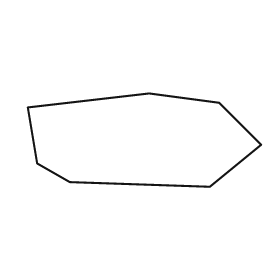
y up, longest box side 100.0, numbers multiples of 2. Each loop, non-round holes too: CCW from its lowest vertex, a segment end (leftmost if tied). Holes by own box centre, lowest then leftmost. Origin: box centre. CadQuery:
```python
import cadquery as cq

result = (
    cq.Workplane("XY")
    .moveTo(28.0, -20.0)
    .lineTo(50.0, -2.0)
    .lineTo(32.0, 16.0)
    .lineTo(2.0, 20.0)
    .lineTo(-50.0, 14.0)
    .lineTo(-46.0, -10.0)
    .lineTo(-32.0, -18.0)
    .close()
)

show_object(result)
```